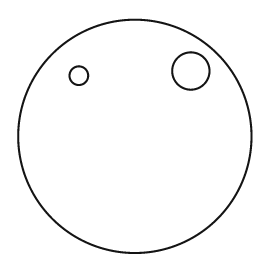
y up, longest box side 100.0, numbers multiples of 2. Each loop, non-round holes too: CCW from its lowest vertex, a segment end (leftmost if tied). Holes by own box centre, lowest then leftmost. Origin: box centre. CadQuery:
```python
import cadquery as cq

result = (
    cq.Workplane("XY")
    .moveTo(0.0, 0.0)
    .circle(50.0)
    .moveTo(-24.0, 26.0)
    .circle(4.0)
    .moveTo(24.0, 28.0)
    .circle(8.0)
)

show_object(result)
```